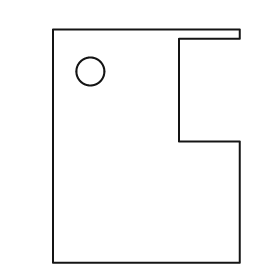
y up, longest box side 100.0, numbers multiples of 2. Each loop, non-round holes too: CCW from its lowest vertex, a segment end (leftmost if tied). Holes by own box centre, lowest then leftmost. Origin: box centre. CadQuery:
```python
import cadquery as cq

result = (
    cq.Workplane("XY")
    .moveTo(-40.0, -50.0)
    .lineTo(40.0, -50.0)
    .lineTo(40.0, 2.0)
    .lineTo(14.0, 2.0)
    .lineTo(14.0, 46.0)
    .lineTo(40.0, 46.0)
    .lineTo(40.0, 50.0)
    .lineTo(-40.0, 50.0)
    .close()
    .moveTo(-24.0, 32.0)
    .circle(6.0)
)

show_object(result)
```